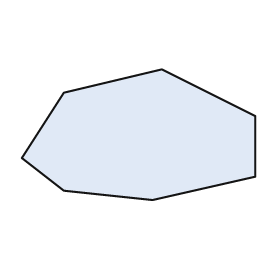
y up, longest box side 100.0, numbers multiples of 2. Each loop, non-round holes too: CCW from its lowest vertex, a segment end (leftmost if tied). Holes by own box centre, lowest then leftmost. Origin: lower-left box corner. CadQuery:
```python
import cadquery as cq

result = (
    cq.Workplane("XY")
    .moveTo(56.0, 0.0)
    .lineTo(100.0, 10.0)
    .lineTo(100.0, 36.0)
    .lineTo(60.0, 56.0)
    .lineTo(18.0, 46.0)
    .lineTo(0.0, 18.0)
    .lineTo(18.0, 4.0)
    .close()
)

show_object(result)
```